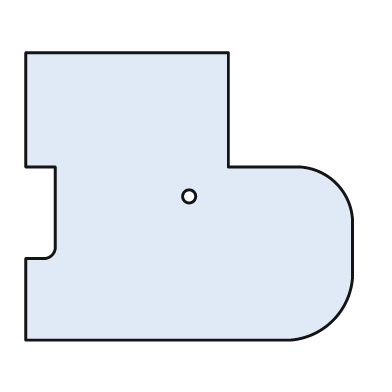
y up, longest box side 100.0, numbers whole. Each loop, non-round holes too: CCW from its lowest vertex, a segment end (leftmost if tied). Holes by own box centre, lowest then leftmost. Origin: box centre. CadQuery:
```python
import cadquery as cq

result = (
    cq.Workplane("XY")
    .moveTo(-50.0, -44.0)
    .lineTo(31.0, -44.0)
    .threePointArc((44.0, -38.0), (50.0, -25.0))
    .lineTo(50.0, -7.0)
    .threePointArc((45.0, 4.0), (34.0, 9.0))
    .lineTo(12.0, 9.0)
    .lineTo(12.0, 44.0)
    .lineTo(-50.0, 44.0)
    .lineTo(-50.0, 9.0)
    .lineTo(-41.0, 9.0)
    .lineTo(-41.0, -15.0)
    .threePointArc((-42.0, -18.0), (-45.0, -19.0))
    .lineTo(-50.0, -19.0)
    .close()
    .moveTo(0.0, 0.0)
    .circle(2.0)
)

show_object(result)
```